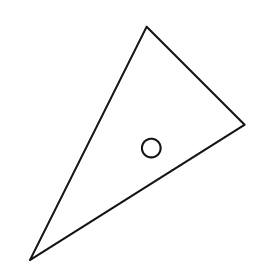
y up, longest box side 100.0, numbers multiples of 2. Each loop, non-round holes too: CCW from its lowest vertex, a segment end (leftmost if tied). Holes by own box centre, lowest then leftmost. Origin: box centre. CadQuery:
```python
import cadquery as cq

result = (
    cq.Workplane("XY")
    .moveTo(-46.0, -50.0)
    .lineTo(46.0, 8.0)
    .lineTo(4.0, 50.0)
    .close()
    .moveTo(6.0, -2.0)
    .circle(4.0)
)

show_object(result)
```